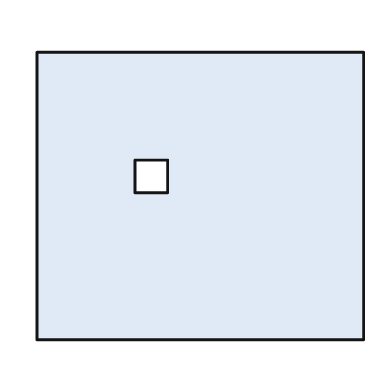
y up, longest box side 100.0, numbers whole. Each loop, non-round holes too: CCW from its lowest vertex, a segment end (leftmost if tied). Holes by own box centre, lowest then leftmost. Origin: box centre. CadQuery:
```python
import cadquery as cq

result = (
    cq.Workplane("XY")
    .moveTo(-50.0, -44.0)
    .lineTo(50.0, -44.0)
    .lineTo(50.0, 44.0)
    .lineTo(-50.0, 44.0)
    .close()
    .moveTo(-20.0, 1.0)
    .lineTo(-10.0, 1.0)
    .lineTo(-10.0, 11.0)
    .lineTo(-20.0, 11.0)
    .close()
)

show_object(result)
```